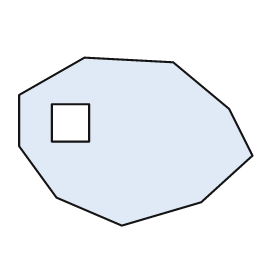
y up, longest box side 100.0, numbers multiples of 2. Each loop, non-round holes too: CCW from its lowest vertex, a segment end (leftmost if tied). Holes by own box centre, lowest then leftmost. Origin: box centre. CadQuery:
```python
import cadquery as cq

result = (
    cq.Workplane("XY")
    .moveTo(-6.0, -36.0)
    .lineTo(28.0, -26.0)
    .lineTo(50.0, -6.0)
    .lineTo(40.0, 14.0)
    .lineTo(16.0, 34.0)
    .lineTo(-22.0, 36.0)
    .lineTo(-50.0, 20.0)
    .lineTo(-50.0, -2.0)
    .lineTo(-34.0, -24.0)
    .close()
    .moveTo(-36.0, 0.0)
    .lineTo(-20.0, 0.0)
    .lineTo(-20.0, 16.0)
    .lineTo(-36.0, 16.0)
    .close()
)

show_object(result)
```